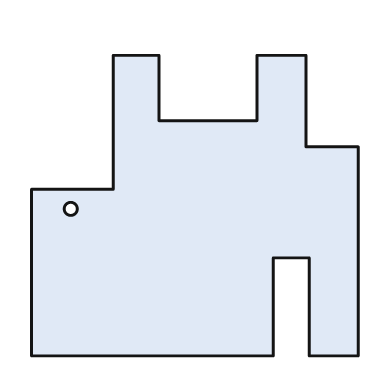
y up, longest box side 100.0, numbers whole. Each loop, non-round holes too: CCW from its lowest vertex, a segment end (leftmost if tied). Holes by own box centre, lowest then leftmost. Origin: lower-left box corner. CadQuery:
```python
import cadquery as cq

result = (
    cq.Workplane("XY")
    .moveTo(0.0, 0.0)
    .lineTo(74.0, 0.0)
    .lineTo(74.0, 30.0)
    .lineTo(85.0, 30.0)
    .lineTo(85.0, 0.0)
    .lineTo(100.0, 0.0)
    .lineTo(100.0, 64.0)
    .lineTo(84.0, 64.0)
    .lineTo(84.0, 92.0)
    .lineTo(69.0, 92.0)
    .lineTo(69.0, 72.0)
    .lineTo(39.0, 72.0)
    .lineTo(39.0, 92.0)
    .lineTo(25.0, 92.0)
    .lineTo(25.0, 51.0)
    .lineTo(0.0, 51.0)
    .close()
    .moveTo(12.0, 45.0)
    .circle(2.0)
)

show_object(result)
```